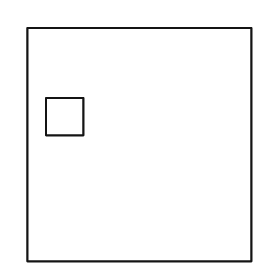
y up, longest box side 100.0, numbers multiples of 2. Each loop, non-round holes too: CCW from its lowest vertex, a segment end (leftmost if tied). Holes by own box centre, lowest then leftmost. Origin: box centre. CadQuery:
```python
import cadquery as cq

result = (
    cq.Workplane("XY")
    .moveTo(-48.0, -50.0)
    .lineTo(48.0, -50.0)
    .lineTo(48.0, 50.0)
    .lineTo(-48.0, 50.0)
    .close()
    .moveTo(-40.0, 4.0)
    .lineTo(-24.0, 4.0)
    .lineTo(-24.0, 20.0)
    .lineTo(-40.0, 20.0)
    .close()
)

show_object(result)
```